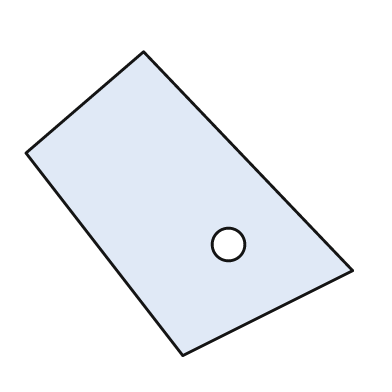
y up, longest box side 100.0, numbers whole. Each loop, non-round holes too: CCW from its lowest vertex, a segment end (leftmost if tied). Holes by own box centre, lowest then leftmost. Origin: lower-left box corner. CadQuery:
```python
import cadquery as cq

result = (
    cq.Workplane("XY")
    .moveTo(48.0, 0.0)
    .lineTo(100.0, 26.0)
    .lineTo(36.0, 93.0)
    .lineTo(0.0, 62.0)
    .close()
    .moveTo(62.0, 34.0)
    .circle(5.0)
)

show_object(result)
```